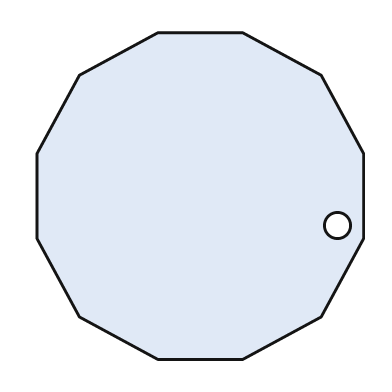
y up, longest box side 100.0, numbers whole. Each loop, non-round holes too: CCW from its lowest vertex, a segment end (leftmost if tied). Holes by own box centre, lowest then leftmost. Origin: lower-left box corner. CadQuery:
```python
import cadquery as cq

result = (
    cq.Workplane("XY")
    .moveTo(37.0, 0.0)
    .lineTo(63.0, 0.0)
    .lineTo(87.0, 13.0)
    .lineTo(100.0, 37.0)
    .lineTo(100.0, 63.0)
    .lineTo(87.0, 87.0)
    .lineTo(63.0, 100.0)
    .lineTo(37.0, 100.0)
    .lineTo(13.0, 87.0)
    .lineTo(0.0, 63.0)
    .lineTo(0.0, 37.0)
    .lineTo(13.0, 13.0)
    .close()
    .moveTo(92.0, 41.0)
    .circle(4.0)
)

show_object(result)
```